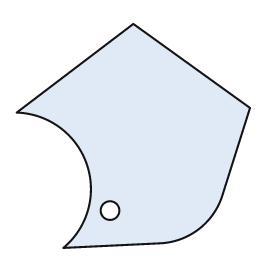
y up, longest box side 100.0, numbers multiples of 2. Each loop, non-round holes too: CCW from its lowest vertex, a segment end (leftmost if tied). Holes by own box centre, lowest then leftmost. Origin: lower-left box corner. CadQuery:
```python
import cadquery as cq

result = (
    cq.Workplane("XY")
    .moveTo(20.0, 0.0)
    .lineTo(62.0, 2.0)
    .threePointArc((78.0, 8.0), (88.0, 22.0))
    .lineTo(100.0, 60.0)
    .lineTo(50.0, 96.0)
    .lineTo(0.0, 58.0)
    .threePointArc((30.0, 36.0), (20.0, 0.0))
    .close()
    .moveTo(40.0, 16.0)
    .circle(4.0)
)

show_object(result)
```